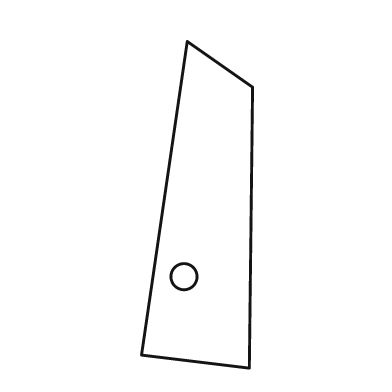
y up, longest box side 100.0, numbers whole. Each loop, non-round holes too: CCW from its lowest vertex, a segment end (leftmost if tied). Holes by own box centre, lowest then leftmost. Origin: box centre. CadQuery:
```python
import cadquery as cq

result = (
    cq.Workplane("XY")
    .moveTo(16.0, -50.0)
    .lineTo(17.0, 36.0)
    .lineTo(-3.0, 50.0)
    .lineTo(-17.0, -46.0)
    .close()
    .moveTo(-4.0, -22.0)
    .circle(4.0)
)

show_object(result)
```